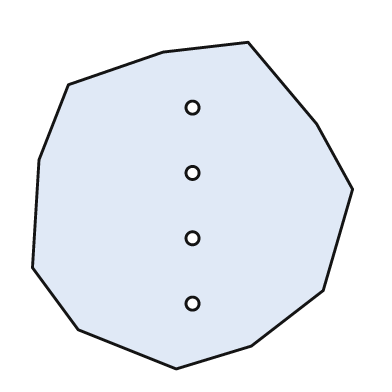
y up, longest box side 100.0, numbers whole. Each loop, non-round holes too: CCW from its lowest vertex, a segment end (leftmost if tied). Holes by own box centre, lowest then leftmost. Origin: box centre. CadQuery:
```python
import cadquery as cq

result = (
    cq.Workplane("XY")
    .moveTo(-5.0, -50.0)
    .lineTo(18.0, -43.0)
    .lineTo(40.0, -26.0)
    .lineTo(49.0, 5.0)
    .lineTo(38.0, 25.0)
    .lineTo(17.0, 50.0)
    .lineTo(-9.0, 47.0)
    .lineTo(-38.0, 37.0)
    .lineTo(-47.0, 14.0)
    .lineTo(-49.0, -19.0)
    .lineTo(-35.0, -38.0)
    .close()
    .moveTo(0.0, -30.0)
    .circle(2.0)
    .moveTo(0.0, -10.0)
    .circle(2.0)
    .moveTo(0.0, 10.0)
    .circle(2.0)
    .moveTo(0.0, 30.0)
    .circle(2.0)
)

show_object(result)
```